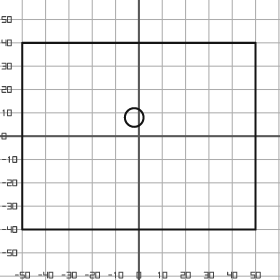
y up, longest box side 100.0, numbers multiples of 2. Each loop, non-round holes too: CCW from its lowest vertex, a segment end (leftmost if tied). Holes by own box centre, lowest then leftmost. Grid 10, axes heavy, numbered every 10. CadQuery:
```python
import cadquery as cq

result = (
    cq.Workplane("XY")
    .moveTo(-50.0, -40.0)
    .lineTo(50.0, -40.0)
    .lineTo(50.0, 40.0)
    .lineTo(-50.0, 40.0)
    .close()
    .moveTo(-2.0, 8.0)
    .circle(4.0)
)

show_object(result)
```